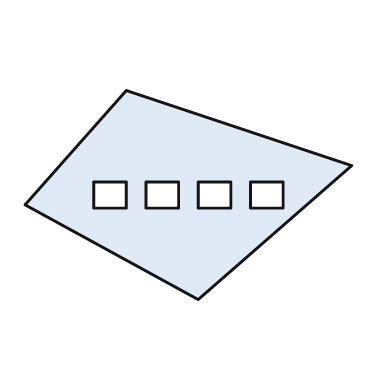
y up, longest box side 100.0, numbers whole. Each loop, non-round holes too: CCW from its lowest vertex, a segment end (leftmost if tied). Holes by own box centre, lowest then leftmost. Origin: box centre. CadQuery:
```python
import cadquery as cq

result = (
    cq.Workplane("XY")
    .moveTo(3.0, -32.0)
    .lineTo(50.0, 9.0)
    .lineTo(-19.0, 32.0)
    .lineTo(-50.0, -3.0)
    .close()
    .moveTo(-29.0, -4.0)
    .lineTo(-19.0, -4.0)
    .lineTo(-19.0, 4.0)
    .lineTo(-29.0, 4.0)
    .close()
    .moveTo(-13.0, -4.0)
    .lineTo(-3.0, -4.0)
    .lineTo(-3.0, 4.0)
    .lineTo(-13.0, 4.0)
    .close()
    .moveTo(3.0, -4.0)
    .lineTo(13.0, -4.0)
    .lineTo(13.0, 4.0)
    .lineTo(3.0, 4.0)
    .close()
    .moveTo(19.0, -4.0)
    .lineTo(29.0, -4.0)
    .lineTo(29.0, 4.0)
    .lineTo(19.0, 4.0)
    .close()
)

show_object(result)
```